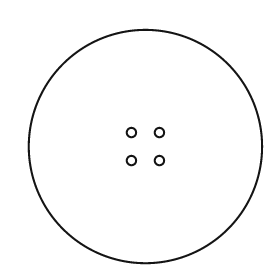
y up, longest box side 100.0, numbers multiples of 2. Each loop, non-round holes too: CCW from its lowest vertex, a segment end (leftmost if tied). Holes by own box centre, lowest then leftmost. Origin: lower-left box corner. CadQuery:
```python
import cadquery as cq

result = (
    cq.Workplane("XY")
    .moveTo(50.0, 50.0)
    .circle(50.0)
    .moveTo(44.0, 44.0)
    .circle(2.0)
    .moveTo(56.0, 44.0)
    .circle(2.0)
    .moveTo(44.0, 56.0)
    .circle(2.0)
    .moveTo(56.0, 56.0)
    .circle(2.0)
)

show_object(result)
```